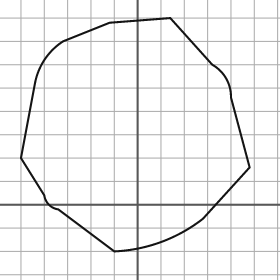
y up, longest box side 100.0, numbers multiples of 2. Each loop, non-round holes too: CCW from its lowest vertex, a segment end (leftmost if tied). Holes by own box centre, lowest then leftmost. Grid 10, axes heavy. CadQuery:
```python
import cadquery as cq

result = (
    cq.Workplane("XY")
    .moveTo(-10.0, -20.0)
    .threePointArc((10.0, -16.0), (28.0, -6.0))
    .lineTo(48.0, 16.0)
    .lineTo(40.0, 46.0)
    .threePointArc((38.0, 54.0), (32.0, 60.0))
    .lineTo(14.0, 80.0)
    .lineTo(-12.0, 78.0)
    .lineTo(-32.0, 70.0)
    .threePointArc((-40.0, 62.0), (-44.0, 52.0))
    .lineTo(-50.0, 20.0)
    .lineTo(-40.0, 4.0)
    .threePointArc((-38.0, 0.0), (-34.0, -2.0))
    .close()
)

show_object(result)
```